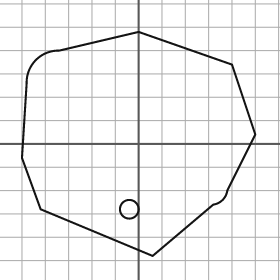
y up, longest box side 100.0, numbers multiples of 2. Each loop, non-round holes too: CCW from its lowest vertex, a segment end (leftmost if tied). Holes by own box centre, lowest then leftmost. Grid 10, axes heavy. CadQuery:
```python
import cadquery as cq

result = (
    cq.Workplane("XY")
    .moveTo(6.0, -48.0)
    .lineTo(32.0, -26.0)
    .threePointArc((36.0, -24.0), (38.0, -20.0))
    .lineTo(50.0, 4.0)
    .lineTo(40.0, 34.0)
    .lineTo(0.0, 48.0)
    .lineTo(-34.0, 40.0)
    .threePointArc((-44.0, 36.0), (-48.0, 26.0))
    .lineTo(-50.0, -6.0)
    .lineTo(-42.0, -28.0)
    .close()
    .moveTo(-4.0, -28.0)
    .circle(4.0)
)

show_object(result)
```